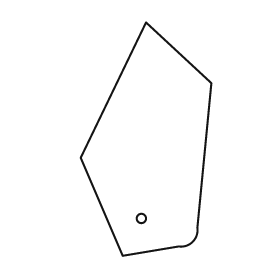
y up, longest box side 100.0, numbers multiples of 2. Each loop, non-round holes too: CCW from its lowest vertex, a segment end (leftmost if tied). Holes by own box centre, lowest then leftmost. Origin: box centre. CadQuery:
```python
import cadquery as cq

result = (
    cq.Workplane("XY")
    .moveTo(-10.0, -50.0)
    .lineTo(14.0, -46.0)
    .threePointArc((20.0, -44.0), (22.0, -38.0))
    .lineTo(28.0, 24.0)
    .lineTo(0.0, 50.0)
    .lineTo(-28.0, -8.0)
    .close()
    .moveTo(-2.0, -34.0)
    .circle(2.0)
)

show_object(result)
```